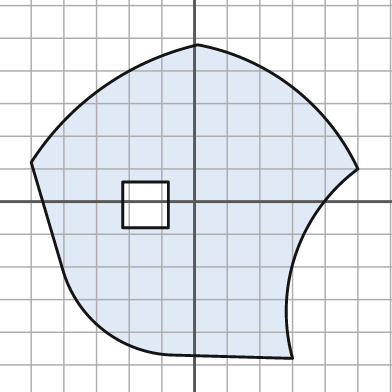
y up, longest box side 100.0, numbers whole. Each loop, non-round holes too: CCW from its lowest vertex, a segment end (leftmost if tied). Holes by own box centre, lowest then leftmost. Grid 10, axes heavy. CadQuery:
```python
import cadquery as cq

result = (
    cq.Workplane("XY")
    .moveTo(30.0, -48.0)
    .threePointArc((31.0, -16.0), (50.0, 10.0))
    .threePointArc((30.0, 35.0), (1.0, 48.0))
    .threePointArc((-28.0, 35.0), (-50.0, 12.0))
    .lineTo(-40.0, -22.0)
    .threePointArc((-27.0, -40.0), (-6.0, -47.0))
    .close()
    .moveTo(-22.0, -8.0)
    .lineTo(-8.0, -8.0)
    .lineTo(-8.0, 6.0)
    .lineTo(-22.0, 6.0)
    .close()
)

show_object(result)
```